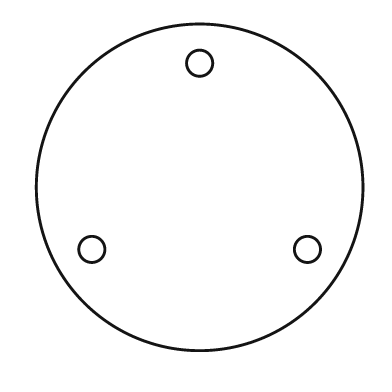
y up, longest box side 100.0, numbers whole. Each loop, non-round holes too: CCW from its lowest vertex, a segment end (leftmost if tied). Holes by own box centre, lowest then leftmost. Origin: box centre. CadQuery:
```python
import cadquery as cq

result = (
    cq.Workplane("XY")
    .moveTo(0.0, 0.0)
    .circle(50.0)
    .moveTo(-33.0, -19.0)
    .circle(4.0)
    .moveTo(33.0, -19.0)
    .circle(4.0)
    .moveTo(0.0, 38.0)
    .circle(4.0)
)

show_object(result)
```